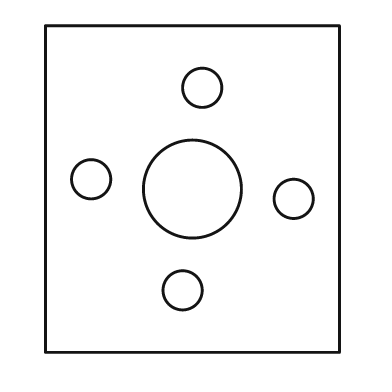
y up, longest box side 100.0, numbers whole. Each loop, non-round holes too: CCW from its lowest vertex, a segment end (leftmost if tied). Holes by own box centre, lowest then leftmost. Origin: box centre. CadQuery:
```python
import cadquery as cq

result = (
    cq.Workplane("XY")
    .moveTo(-45.0, -50.0)
    .lineTo(45.0, -50.0)
    .lineTo(45.0, 50.0)
    .lineTo(-45.0, 50.0)
    .close()
    .moveTo(-3.0, -31.0)
    .circle(6.0)
    .moveTo(31.0, -3.0)
    .circle(6.0)
    .moveTo(0.0, 0.0)
    .circle(15.0)
    .moveTo(-31.0, 3.0)
    .circle(6.0)
    .moveTo(3.0, 31.0)
    .circle(6.0)
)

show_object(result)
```